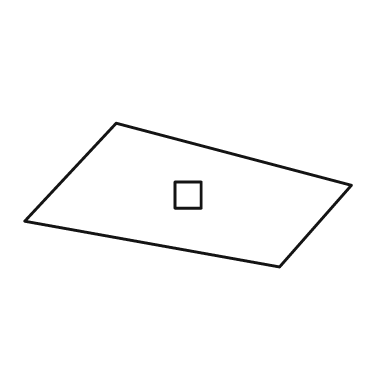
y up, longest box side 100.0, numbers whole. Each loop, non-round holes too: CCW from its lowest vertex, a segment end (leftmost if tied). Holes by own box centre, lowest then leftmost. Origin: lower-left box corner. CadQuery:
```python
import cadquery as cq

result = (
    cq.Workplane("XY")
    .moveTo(78.0, 0.0)
    .lineTo(100.0, 25.0)
    .lineTo(28.0, 44.0)
    .lineTo(0.0, 14.0)
    .close()
    .moveTo(46.0, 18.0)
    .lineTo(54.0, 18.0)
    .lineTo(54.0, 26.0)
    .lineTo(46.0, 26.0)
    .close()
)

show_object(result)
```